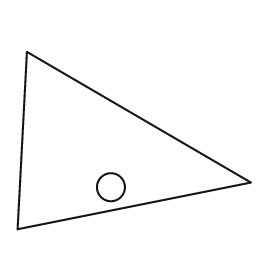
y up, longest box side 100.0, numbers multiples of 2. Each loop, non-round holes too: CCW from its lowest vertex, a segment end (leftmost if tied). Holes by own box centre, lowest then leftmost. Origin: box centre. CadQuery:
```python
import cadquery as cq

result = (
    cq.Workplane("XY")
    .moveTo(-50.0, -38.0)
    .lineTo(50.0, -18.0)
    .lineTo(-46.0, 38.0)
    .close()
    .moveTo(-10.0, -20.0)
    .circle(6.0)
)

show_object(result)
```